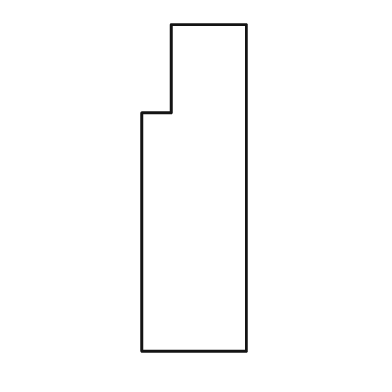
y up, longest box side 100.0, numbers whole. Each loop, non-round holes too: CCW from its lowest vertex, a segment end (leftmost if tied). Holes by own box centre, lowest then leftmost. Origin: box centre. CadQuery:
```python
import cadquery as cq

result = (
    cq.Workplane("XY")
    .moveTo(-16.0, -50.0)
    .lineTo(16.0, -50.0)
    .lineTo(16.0, 50.0)
    .lineTo(-7.0, 50.0)
    .lineTo(-7.0, 23.0)
    .lineTo(-16.0, 23.0)
    .close()
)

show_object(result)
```